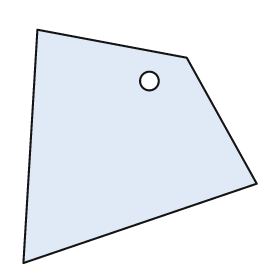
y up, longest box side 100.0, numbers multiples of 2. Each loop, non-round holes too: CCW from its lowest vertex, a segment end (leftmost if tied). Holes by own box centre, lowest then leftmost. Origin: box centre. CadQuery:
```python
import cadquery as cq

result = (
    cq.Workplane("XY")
    .moveTo(-50.0, -50.0)
    .lineTo(50.0, -16.0)
    .lineTo(20.0, 38.0)
    .lineTo(-44.0, 50.0)
    .close()
    .moveTo(4.0, 28.0)
    .circle(4.0)
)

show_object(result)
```